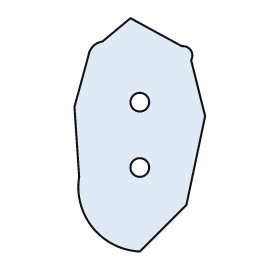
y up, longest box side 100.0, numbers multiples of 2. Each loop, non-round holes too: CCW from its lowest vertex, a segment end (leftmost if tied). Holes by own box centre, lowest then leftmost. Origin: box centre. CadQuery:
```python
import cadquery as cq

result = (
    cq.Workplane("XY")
    .moveTo(0.0, -50.0)
    .lineTo(20.0, -30.0)
    .lineTo(28.0, 8.0)
    .lineTo(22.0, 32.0)
    .threePointArc((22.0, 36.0), (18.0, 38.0))
    .lineTo(-4.0, 50.0)
    .lineTo(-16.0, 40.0)
    .threePointArc((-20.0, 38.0), (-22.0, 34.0))
    .lineTo(-28.0, 12.0)
    .lineTo(-26.0, -18.0)
    .threePointArc((-20.0, -40.0), (0.0, -50.0))
    .close()
    .moveTo(0.0, -14.0)
    .circle(4.0)
    .moveTo(0.0, 14.0)
    .circle(4.0)
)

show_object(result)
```